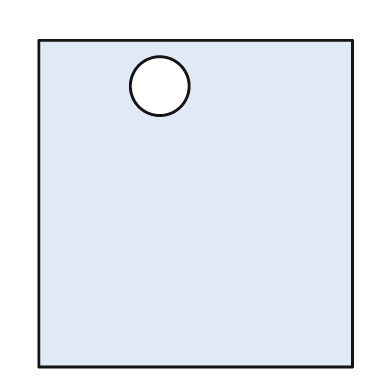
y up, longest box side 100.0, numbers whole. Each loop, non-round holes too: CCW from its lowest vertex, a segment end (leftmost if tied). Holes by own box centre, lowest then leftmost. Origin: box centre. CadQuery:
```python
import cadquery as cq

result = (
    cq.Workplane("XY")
    .moveTo(-48.0, -50.0)
    .lineTo(48.0, -50.0)
    .lineTo(48.0, 50.0)
    .lineTo(-48.0, 50.0)
    .close()
    .moveTo(-11.0, 36.0)
    .circle(9.0)
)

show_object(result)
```